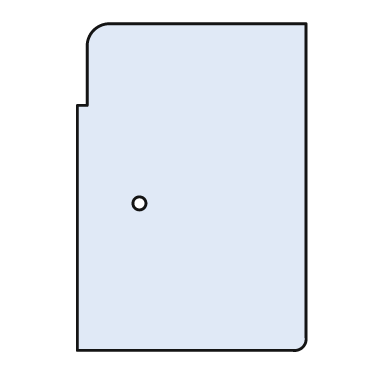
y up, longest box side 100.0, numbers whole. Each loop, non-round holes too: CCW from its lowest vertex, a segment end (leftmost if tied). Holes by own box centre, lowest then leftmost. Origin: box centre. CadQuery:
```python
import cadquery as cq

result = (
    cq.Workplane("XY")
    .moveTo(-35.0, -50.0)
    .lineTo(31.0, -50.0)
    .threePointArc((34.0, -49.0), (35.0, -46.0))
    .lineTo(35.0, 50.0)
    .lineTo(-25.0, 50.0)
    .threePointArc((-30.0, 48.0), (-32.0, 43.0))
    .lineTo(-32.0, 25.0)
    .lineTo(-35.0, 25.0)
    .close()
    .moveTo(-16.0, -5.0)
    .circle(2.0)
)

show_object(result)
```